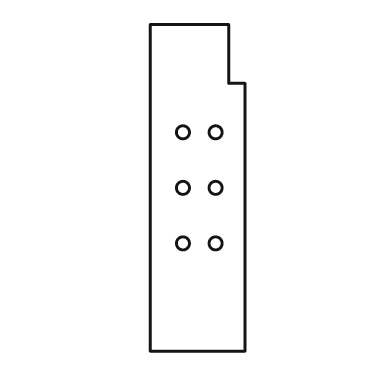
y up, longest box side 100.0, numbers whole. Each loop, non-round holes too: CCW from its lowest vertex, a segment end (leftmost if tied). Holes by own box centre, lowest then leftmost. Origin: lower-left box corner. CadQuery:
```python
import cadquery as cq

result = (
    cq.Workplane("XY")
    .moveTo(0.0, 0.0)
    .lineTo(29.0, 0.0)
    .lineTo(29.0, 82.0)
    .lineTo(24.0, 82.0)
    .lineTo(24.0, 100.0)
    .lineTo(0.0, 100.0)
    .close()
    .moveTo(10.0, 33.0)
    .circle(2.0)
    .moveTo(20.0, 33.0)
    .circle(2.0)
    .moveTo(10.0, 50.0)
    .circle(2.0)
    .moveTo(20.0, 50.0)
    .circle(2.0)
    .moveTo(10.0, 67.0)
    .circle(2.0)
    .moveTo(20.0, 67.0)
    .circle(2.0)
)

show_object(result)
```